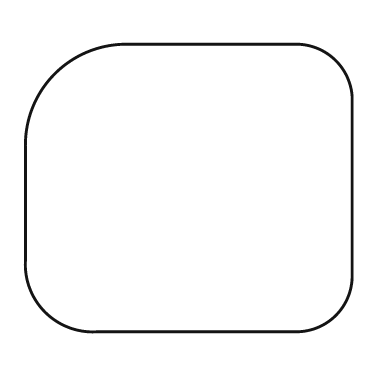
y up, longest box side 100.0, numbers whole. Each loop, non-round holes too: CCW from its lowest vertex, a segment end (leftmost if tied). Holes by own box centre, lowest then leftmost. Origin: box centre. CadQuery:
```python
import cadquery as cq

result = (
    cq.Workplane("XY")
    .moveTo(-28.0, -44.0)
    .lineTo(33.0, -44.0)
    .threePointArc((45.0, -39.0), (50.0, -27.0))
    .lineTo(50.0, 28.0)
    .threePointArc((45.0, 39.0), (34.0, 44.0))
    .lineTo(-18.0, 44.0)
    .threePointArc((-41.0, 35.0), (-50.0, 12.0))
    .lineTo(-50.0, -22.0)
    .threePointArc((-44.0, -38.0), (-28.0, -44.0))
    .close()
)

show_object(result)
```